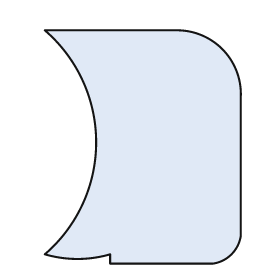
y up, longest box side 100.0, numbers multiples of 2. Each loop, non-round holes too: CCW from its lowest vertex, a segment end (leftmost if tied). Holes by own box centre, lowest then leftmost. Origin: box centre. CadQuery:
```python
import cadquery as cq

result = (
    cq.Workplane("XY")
    .moveTo(-14.0, -50.0)
    .lineTo(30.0, -50.0)
    .threePointArc((38.0, -46.0), (42.0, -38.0))
    .lineTo(42.0, 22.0)
    .threePointArc((34.0, 42.0), (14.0, 50.0))
    .lineTo(-42.0, 50.0)
    .threePointArc((-20.0, 2.0), (-42.0, -46.0))
    .threePointArc((-28.0, -48.0), (-14.0, -46.0))
    .close()
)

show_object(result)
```